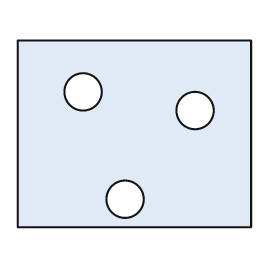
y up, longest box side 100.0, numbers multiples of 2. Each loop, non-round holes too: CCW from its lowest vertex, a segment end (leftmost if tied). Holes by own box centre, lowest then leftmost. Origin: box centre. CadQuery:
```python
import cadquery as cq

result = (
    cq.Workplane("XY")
    .moveTo(-50.0, -40.0)
    .lineTo(50.0, -40.0)
    .lineTo(50.0, 40.0)
    .lineTo(-50.0, 40.0)
    .close()
    .moveTo(-4.0, -28.0)
    .circle(8.0)
    .moveTo(26.0, 10.0)
    .circle(8.0)
    .moveTo(-22.0, 18.0)
    .circle(8.0)
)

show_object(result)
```